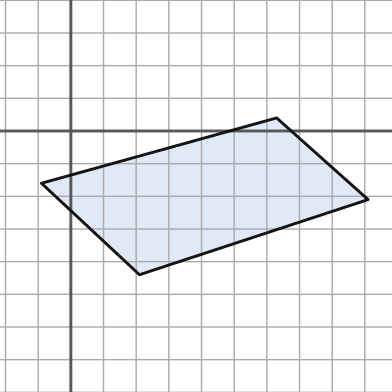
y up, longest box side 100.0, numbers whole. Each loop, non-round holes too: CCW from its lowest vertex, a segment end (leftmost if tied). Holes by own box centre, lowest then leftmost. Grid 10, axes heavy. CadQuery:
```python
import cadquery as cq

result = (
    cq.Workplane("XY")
    .moveTo(21.0, -44.0)
    .lineTo(91.0, -21.0)
    .lineTo(63.0, 4.0)
    .lineTo(-9.0, -16.0)
    .close()
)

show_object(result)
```